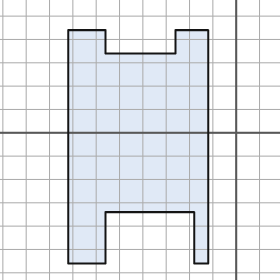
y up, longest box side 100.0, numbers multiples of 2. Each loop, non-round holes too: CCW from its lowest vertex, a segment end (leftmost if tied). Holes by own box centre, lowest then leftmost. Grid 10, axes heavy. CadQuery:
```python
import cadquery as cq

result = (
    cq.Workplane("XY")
    .moveTo(-72.0, -56.0)
    .lineTo(-56.0, -56.0)
    .lineTo(-56.0, -34.0)
    .lineTo(-18.0, -34.0)
    .lineTo(-18.0, -56.0)
    .lineTo(-12.0, -56.0)
    .lineTo(-12.0, 44.0)
    .lineTo(-26.0, 44.0)
    .lineTo(-26.0, 34.0)
    .lineTo(-56.0, 34.0)
    .lineTo(-56.0, 44.0)
    .lineTo(-72.0, 44.0)
    .close()
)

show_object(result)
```